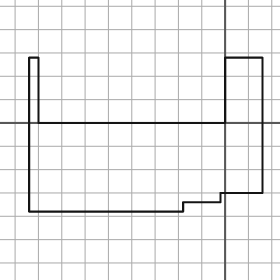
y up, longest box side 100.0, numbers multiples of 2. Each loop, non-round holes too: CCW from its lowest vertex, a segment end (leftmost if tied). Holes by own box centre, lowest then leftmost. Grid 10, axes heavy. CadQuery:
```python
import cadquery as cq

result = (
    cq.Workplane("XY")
    .moveTo(-84.0, -38.0)
    .lineTo(-18.0, -38.0)
    .lineTo(-18.0, -34.0)
    .lineTo(-2.0, -34.0)
    .lineTo(-2.0, -30.0)
    .lineTo(16.0, -30.0)
    .lineTo(16.0, 28.0)
    .lineTo(0.0, 28.0)
    .lineTo(0.0, 0.0)
    .lineTo(-80.0, 0.0)
    .lineTo(-80.0, 28.0)
    .lineTo(-84.0, 28.0)
    .close()
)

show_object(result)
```